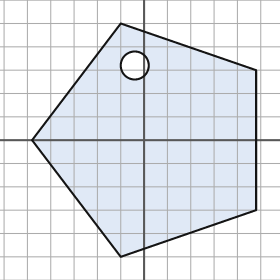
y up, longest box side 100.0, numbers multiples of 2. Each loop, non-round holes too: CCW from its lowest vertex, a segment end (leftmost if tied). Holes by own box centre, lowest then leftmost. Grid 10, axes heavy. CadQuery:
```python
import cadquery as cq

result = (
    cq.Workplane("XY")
    .moveTo(-10.0, -50.0)
    .lineTo(48.0, -30.0)
    .lineTo(48.0, 30.0)
    .lineTo(-10.0, 50.0)
    .lineTo(-48.0, 0.0)
    .close()
    .moveTo(-4.0, 32.0)
    .circle(6.0)
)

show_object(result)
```